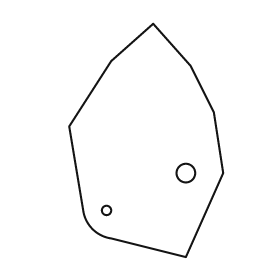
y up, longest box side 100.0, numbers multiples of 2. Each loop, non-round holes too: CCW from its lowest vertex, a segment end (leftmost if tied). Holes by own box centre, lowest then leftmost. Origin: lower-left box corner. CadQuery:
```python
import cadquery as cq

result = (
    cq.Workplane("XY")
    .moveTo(50.0, 0.0)
    .lineTo(66.0, 36.0)
    .lineTo(62.0, 62.0)
    .lineTo(52.0, 82.0)
    .lineTo(36.0, 100.0)
    .lineTo(18.0, 84.0)
    .lineTo(0.0, 56.0)
    .lineTo(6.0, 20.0)
    .threePointArc((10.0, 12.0), (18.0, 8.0))
    .close()
    .moveTo(16.0, 20.0)
    .circle(2.0)
    .moveTo(50.0, 36.0)
    .circle(4.0)
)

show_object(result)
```